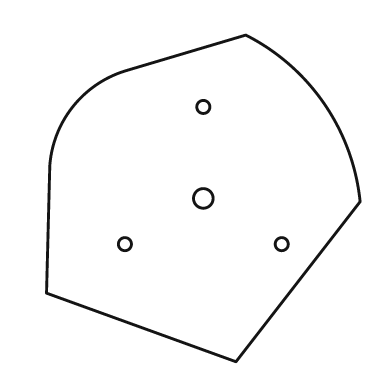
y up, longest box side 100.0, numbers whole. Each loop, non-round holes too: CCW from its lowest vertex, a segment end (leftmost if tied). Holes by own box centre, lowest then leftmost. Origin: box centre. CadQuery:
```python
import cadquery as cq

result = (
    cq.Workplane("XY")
    .moveTo(10.0, -50.0)
    .lineTo(48.0, -1.0)
    .threePointArc((37.0, 29.0), (13.0, 50.0))
    .lineTo(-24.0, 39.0)
    .threePointArc((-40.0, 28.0), (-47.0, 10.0))
    .lineTo(-48.0, -29.0)
    .close()
    .moveTo(-24.0, -14.0)
    .circle(2.0)
    .moveTo(24.0, -14.0)
    .circle(2.0)
    .moveTo(0.0, 0.0)
    .circle(3.0)
    .moveTo(0.0, 28.0)
    .circle(2.0)
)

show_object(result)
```